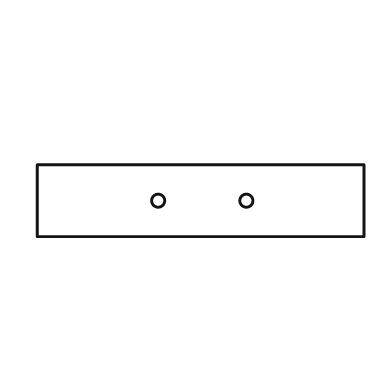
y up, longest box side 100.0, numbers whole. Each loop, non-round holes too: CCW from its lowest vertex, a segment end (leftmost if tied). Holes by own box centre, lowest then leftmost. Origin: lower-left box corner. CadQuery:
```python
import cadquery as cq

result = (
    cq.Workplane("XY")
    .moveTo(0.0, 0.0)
    .lineTo(100.0, 0.0)
    .lineTo(100.0, 22.0)
    .lineTo(0.0, 22.0)
    .close()
    .moveTo(37.0, 11.0)
    .circle(2.0)
    .moveTo(64.0, 11.0)
    .circle(2.0)
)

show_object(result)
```